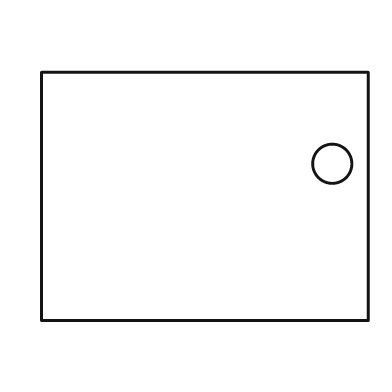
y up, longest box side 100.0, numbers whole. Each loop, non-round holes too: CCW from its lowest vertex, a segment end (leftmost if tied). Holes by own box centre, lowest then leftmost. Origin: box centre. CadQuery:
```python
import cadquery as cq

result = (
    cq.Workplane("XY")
    .moveTo(-50.0, -38.0)
    .lineTo(50.0, -38.0)
    .lineTo(50.0, 38.0)
    .lineTo(-50.0, 38.0)
    .close()
    .moveTo(39.0, 10.0)
    .circle(6.0)
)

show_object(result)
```